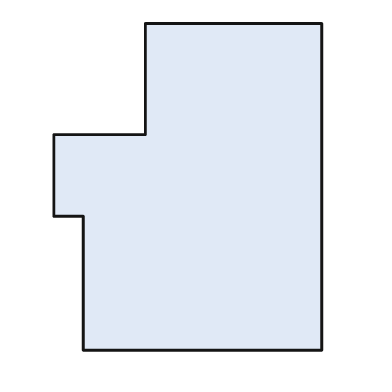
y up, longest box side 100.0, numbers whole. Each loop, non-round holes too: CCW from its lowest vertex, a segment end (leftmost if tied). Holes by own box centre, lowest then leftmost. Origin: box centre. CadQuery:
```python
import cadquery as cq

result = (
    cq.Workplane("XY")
    .moveTo(-32.0, -50.0)
    .lineTo(41.0, -50.0)
    .lineTo(41.0, 50.0)
    .lineTo(-13.0, 50.0)
    .lineTo(-13.0, 16.0)
    .lineTo(-41.0, 16.0)
    .lineTo(-41.0, -9.0)
    .lineTo(-32.0, -9.0)
    .close()
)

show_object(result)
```